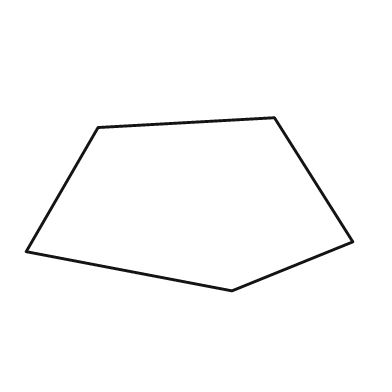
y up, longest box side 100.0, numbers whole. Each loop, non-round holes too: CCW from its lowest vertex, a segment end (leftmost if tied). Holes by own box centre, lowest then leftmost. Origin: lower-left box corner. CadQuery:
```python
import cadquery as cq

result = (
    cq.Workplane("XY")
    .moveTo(63.0, 0.0)
    .lineTo(100.0, 15.0)
    .lineTo(76.0, 53.0)
    .lineTo(22.0, 50.0)
    .lineTo(0.0, 12.0)
    .close()
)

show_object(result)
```